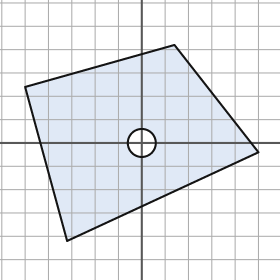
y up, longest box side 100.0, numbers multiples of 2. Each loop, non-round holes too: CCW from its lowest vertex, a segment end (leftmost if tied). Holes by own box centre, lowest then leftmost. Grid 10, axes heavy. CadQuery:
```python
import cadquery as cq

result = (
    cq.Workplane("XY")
    .moveTo(-32.0, -42.0)
    .lineTo(50.0, -4.0)
    .lineTo(14.0, 42.0)
    .lineTo(-50.0, 24.0)
    .close()
    .moveTo(0.0, 0.0)
    .circle(6.0)
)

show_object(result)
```